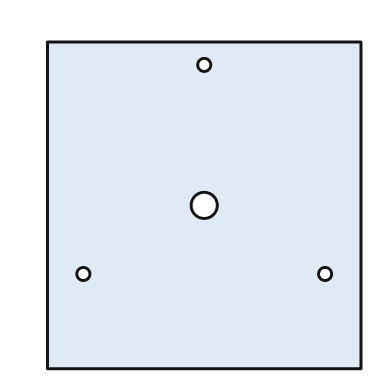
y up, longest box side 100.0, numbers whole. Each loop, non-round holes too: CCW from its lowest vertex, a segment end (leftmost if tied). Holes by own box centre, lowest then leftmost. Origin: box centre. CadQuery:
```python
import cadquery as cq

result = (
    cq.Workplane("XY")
    .moveTo(-48.0, -50.0)
    .lineTo(48.0, -50.0)
    .lineTo(48.0, 50.0)
    .lineTo(-48.0, 50.0)
    .close()
    .moveTo(-37.0, -21.0)
    .circle(2.0)
    .moveTo(37.0, -21.0)
    .circle(2.0)
    .moveTo(0.0, 0.0)
    .circle(4.0)
    .moveTo(0.0, 43.0)
    .circle(2.0)
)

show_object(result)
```